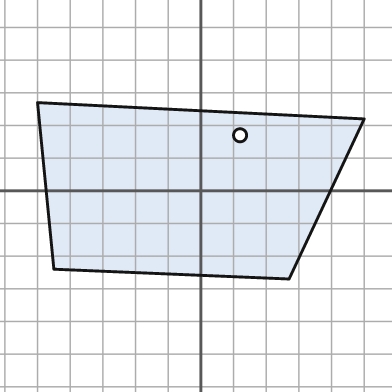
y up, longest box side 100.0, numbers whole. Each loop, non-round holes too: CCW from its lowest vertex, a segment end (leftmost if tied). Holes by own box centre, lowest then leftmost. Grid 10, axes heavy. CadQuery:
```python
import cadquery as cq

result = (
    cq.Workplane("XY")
    .moveTo(27.0, -27.0)
    .lineTo(50.0, 22.0)
    .lineTo(-50.0, 27.0)
    .lineTo(-45.0, -24.0)
    .close()
    .moveTo(12.0, 17.0)
    .circle(2.0)
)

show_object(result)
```